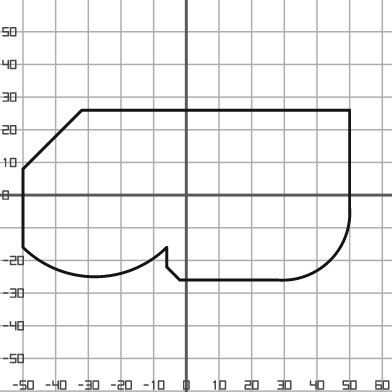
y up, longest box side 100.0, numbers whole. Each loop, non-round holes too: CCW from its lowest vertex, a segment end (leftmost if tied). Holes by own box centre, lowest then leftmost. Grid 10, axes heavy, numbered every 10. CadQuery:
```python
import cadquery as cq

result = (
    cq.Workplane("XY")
    .moveTo(-2.0, -26.0)
    .lineTo(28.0, -26.0)
    .threePointArc((44.0, -20.0), (50.0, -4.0))
    .lineTo(50.0, 26.0)
    .lineTo(-32.0, 26.0)
    .lineTo(-50.0, 8.0)
    .lineTo(-50.0, -16.0)
    .threePointArc((-28.0, -25.0), (-6.0, -16.0))
    .lineTo(-6.0, -22.0)
    .close()
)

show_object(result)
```